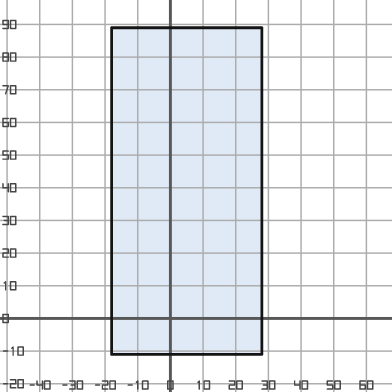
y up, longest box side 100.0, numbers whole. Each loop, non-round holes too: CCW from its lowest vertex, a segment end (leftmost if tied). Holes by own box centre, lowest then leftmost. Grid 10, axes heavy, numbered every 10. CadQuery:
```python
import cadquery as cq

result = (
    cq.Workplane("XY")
    .moveTo(-18.0, -11.0)
    .lineTo(28.0, -11.0)
    .lineTo(28.0, 89.0)
    .lineTo(-18.0, 89.0)
    .close()
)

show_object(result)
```